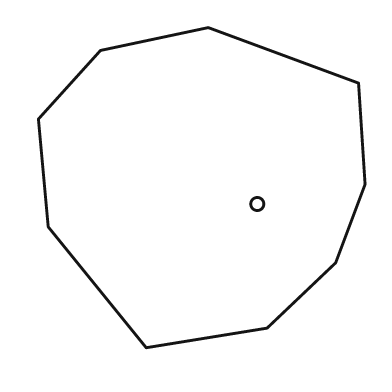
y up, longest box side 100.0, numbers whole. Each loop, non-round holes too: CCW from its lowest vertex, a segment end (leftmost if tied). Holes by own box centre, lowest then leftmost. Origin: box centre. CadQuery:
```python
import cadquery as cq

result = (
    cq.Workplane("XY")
    .moveTo(-17.0, -49.0)
    .lineTo(20.0, -43.0)
    .lineTo(41.0, -23.0)
    .lineTo(50.0, 1.0)
    .lineTo(48.0, 32.0)
    .lineTo(2.0, 49.0)
    .lineTo(-31.0, 42.0)
    .lineTo(-50.0, 21.0)
    .lineTo(-47.0, -12.0)
    .close()
    .moveTo(17.0, -5.0)
    .circle(2.0)
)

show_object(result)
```